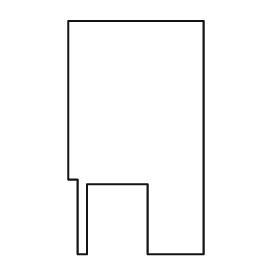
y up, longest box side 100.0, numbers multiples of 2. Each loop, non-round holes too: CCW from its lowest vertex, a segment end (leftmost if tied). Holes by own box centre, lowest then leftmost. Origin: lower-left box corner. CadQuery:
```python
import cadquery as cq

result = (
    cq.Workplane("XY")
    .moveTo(4.0, 0.0)
    .lineTo(8.0, 0.0)
    .lineTo(8.0, 30.0)
    .lineTo(34.0, 30.0)
    .lineTo(34.0, 0.0)
    .lineTo(58.0, 0.0)
    .lineTo(58.0, 100.0)
    .lineTo(0.0, 100.0)
    .lineTo(0.0, 32.0)
    .lineTo(4.0, 32.0)
    .close()
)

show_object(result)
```